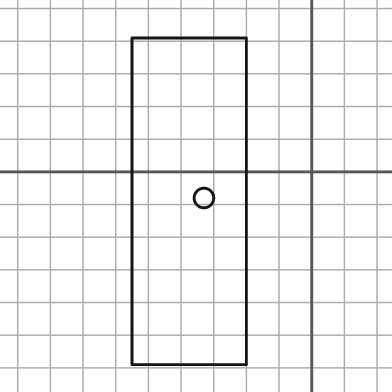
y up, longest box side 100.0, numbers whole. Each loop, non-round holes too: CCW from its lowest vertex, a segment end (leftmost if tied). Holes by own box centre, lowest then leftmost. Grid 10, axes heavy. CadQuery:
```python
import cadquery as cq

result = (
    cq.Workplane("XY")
    .moveTo(-55.0, -59.0)
    .lineTo(-20.0, -59.0)
    .lineTo(-20.0, 41.0)
    .lineTo(-55.0, 41.0)
    .close()
    .moveTo(-33.0, -8.0)
    .circle(3.0)
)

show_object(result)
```